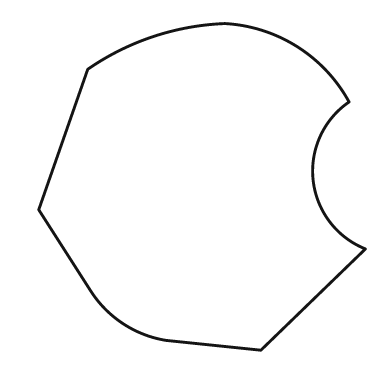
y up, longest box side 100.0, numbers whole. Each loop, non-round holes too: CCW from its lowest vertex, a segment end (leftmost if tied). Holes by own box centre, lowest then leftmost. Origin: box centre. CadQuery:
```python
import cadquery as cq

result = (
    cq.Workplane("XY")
    .moveTo(18.0, -50.0)
    .lineTo(50.0, -19.0)
    .threePointArc((34.0, 2.0), (45.0, 26.0))
    .threePointArc((29.0, 43.0), (7.0, 50.0))
    .threePointArc((-15.0, 46.0), (-35.0, 36.0))
    .lineTo(-50.0, -7.0)
    .lineTo(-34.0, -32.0)
    .threePointArc((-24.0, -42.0), (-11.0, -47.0))
    .close()
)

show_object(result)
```